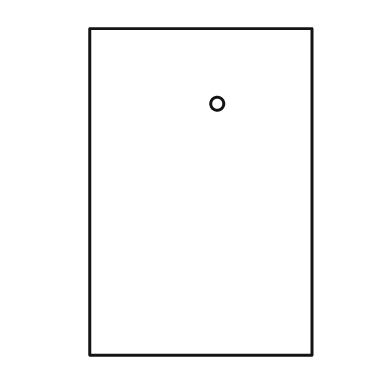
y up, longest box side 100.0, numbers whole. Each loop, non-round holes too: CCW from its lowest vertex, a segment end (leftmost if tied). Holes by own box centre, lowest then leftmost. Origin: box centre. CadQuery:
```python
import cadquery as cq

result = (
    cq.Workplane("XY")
    .moveTo(-34.0, -50.0)
    .lineTo(34.0, -50.0)
    .lineTo(34.0, 50.0)
    .lineTo(-34.0, 50.0)
    .close()
    .moveTo(5.0, 27.0)
    .circle(2.0)
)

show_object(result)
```